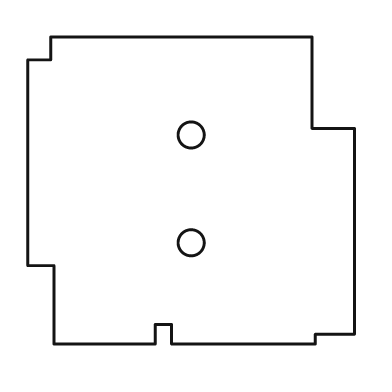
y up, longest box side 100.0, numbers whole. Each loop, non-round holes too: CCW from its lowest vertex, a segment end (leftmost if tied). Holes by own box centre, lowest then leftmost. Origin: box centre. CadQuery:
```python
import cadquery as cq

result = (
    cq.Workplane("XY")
    .moveTo(-42.0, -47.0)
    .lineTo(-11.0, -47.0)
    .lineTo(-11.0, -41.0)
    .lineTo(-6.0, -41.0)
    .lineTo(-6.0, -47.0)
    .lineTo(38.0, -47.0)
    .lineTo(38.0, -44.0)
    .lineTo(50.0, -44.0)
    .lineTo(50.0, 19.0)
    .lineTo(37.0, 19.0)
    .lineTo(37.0, 47.0)
    .lineTo(-43.0, 47.0)
    .lineTo(-43.0, 40.0)
    .lineTo(-50.0, 40.0)
    .lineTo(-50.0, -23.0)
    .lineTo(-42.0, -23.0)
    .close()
    .moveTo(0.0, -16.0)
    .circle(4.0)
    .moveTo(0.0, 17.0)
    .circle(4.0)
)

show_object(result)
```